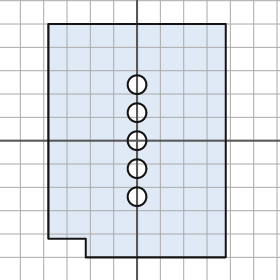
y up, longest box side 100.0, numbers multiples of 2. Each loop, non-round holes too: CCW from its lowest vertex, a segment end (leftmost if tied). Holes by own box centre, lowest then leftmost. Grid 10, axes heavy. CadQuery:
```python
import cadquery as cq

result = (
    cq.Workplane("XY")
    .moveTo(-22.0, -50.0)
    .lineTo(38.0, -50.0)
    .lineTo(38.0, 50.0)
    .lineTo(-38.0, 50.0)
    .lineTo(-38.0, -42.0)
    .lineTo(-22.0, -42.0)
    .close()
    .moveTo(0.0, -24.0)
    .circle(4.0)
    .moveTo(0.0, -12.0)
    .circle(4.0)
    .moveTo(0.0, 0.0)
    .circle(4.0)
    .moveTo(0.0, 12.0)
    .circle(4.0)
    .moveTo(0.0, 24.0)
    .circle(4.0)
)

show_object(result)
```